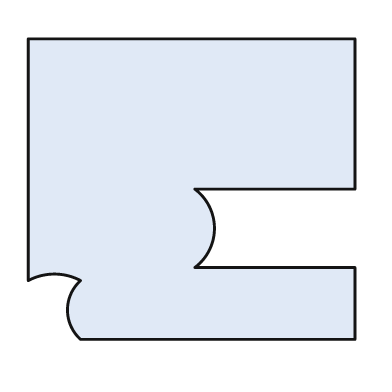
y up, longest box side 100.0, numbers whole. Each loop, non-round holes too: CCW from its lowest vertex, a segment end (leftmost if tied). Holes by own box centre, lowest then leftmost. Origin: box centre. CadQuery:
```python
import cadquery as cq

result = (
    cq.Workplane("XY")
    .moveTo(-34.0, -46.0)
    .lineTo(50.0, -46.0)
    .lineTo(50.0, -24.0)
    .lineTo(1.0, -24.0)
    .threePointArc((7.0, -12.0), (1.0, 0.0))
    .lineTo(50.0, 0.0)
    .lineTo(50.0, 46.0)
    .lineTo(-50.0, 46.0)
    .lineTo(-50.0, -28.0)
    .threePointArc((-42.0, -26.0), (-34.0, -28.0))
    .threePointArc((-38.0, -37.0), (-34.0, -46.0))
    .close()
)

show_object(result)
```